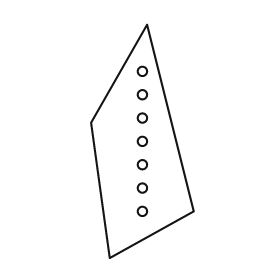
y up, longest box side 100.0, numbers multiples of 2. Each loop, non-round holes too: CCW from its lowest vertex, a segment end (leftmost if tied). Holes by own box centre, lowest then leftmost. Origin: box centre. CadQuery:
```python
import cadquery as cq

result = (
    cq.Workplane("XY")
    .moveTo(-14.0, -50.0)
    .lineTo(22.0, -30.0)
    .lineTo(2.0, 50.0)
    .lineTo(-22.0, 8.0)
    .close()
    .moveTo(0.0, -30.0)
    .circle(2.0)
    .moveTo(0.0, -20.0)
    .circle(2.0)
    .moveTo(0.0, -10.0)
    .circle(2.0)
    .moveTo(0.0, 0.0)
    .circle(2.0)
    .moveTo(0.0, 10.0)
    .circle(2.0)
    .moveTo(0.0, 20.0)
    .circle(2.0)
    .moveTo(0.0, 30.0)
    .circle(2.0)
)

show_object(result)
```